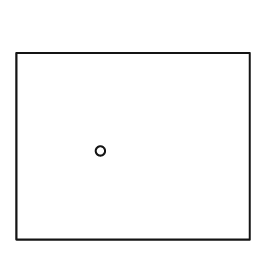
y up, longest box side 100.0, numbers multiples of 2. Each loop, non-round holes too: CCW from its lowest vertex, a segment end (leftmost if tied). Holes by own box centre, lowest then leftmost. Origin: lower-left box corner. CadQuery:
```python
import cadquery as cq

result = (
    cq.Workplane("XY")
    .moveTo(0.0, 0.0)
    .lineTo(100.0, 0.0)
    .lineTo(100.0, 80.0)
    .lineTo(0.0, 80.0)
    .close()
    .moveTo(36.0, 38.0)
    .circle(2.0)
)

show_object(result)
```